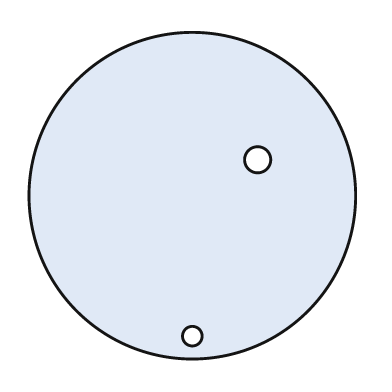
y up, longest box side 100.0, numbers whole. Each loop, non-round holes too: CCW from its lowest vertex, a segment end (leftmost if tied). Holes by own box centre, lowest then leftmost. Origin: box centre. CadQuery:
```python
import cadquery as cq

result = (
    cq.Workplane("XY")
    .moveTo(0.0, 0.0)
    .circle(50.0)
    .moveTo(0.0, -43.0)
    .circle(3.0)
    .moveTo(20.0, 11.0)
    .circle(4.0)
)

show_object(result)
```